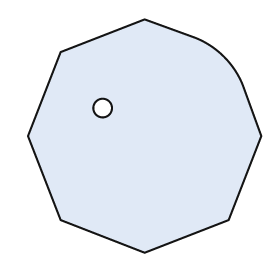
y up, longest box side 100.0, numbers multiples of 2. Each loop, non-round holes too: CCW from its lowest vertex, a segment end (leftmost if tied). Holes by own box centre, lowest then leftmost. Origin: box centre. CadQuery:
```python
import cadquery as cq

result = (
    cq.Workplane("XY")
    .moveTo(0.0, -50.0)
    .lineTo(36.0, -36.0)
    .lineTo(50.0, 0.0)
    .lineTo(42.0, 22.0)
    .threePointArc((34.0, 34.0), (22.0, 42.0))
    .lineTo(0.0, 50.0)
    .lineTo(-36.0, 36.0)
    .lineTo(-50.0, 0.0)
    .lineTo(-36.0, -36.0)
    .close()
    .moveTo(-18.0, 12.0)
    .circle(4.0)
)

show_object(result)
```